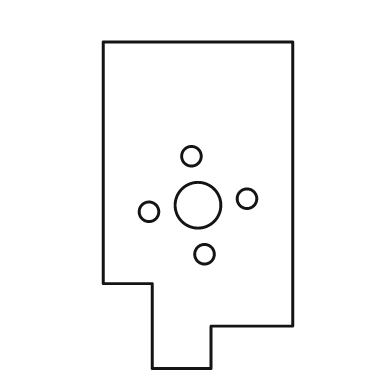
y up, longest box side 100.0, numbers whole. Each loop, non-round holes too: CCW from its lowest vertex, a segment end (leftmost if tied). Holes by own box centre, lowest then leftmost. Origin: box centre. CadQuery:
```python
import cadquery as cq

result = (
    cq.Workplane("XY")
    .moveTo(-14.0, -50.0)
    .lineTo(4.0, -50.0)
    .lineTo(4.0, -37.0)
    .lineTo(29.0, -37.0)
    .lineTo(29.0, 50.0)
    .lineTo(-29.0, 50.0)
    .lineTo(-29.0, -24.0)
    .lineTo(-14.0, -24.0)
    .close()
    .moveTo(2.0, -15.0)
    .circle(3.0)
    .moveTo(-15.0, -2.0)
    .circle(3.0)
    .moveTo(0.0, 0.0)
    .circle(7.0)
    .moveTo(15.0, 2.0)
    .circle(3.0)
    .moveTo(-2.0, 15.0)
    .circle(3.0)
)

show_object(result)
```